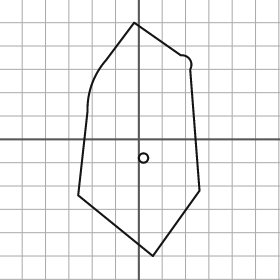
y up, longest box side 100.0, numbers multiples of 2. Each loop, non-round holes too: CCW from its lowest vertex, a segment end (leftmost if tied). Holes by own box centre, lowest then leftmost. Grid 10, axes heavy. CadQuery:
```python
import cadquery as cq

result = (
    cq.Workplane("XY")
    .moveTo(6.0, -50.0)
    .lineTo(26.0, -22.0)
    .lineTo(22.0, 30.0)
    .threePointArc((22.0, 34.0), (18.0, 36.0))
    .lineTo(-2.0, 50.0)
    .lineTo(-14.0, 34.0)
    .threePointArc((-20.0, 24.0), (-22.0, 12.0))
    .lineTo(-26.0, -24.0)
    .close()
    .moveTo(2.0, -8.0)
    .circle(2.0)
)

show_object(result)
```